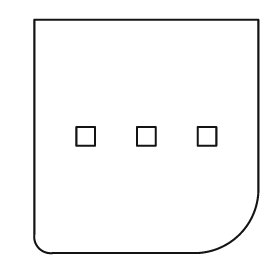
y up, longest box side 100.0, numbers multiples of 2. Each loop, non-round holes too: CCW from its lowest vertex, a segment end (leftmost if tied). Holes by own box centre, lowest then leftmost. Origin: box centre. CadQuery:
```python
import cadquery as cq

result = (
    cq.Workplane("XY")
    .moveTo(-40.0, -50.0)
    .lineTo(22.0, -50.0)
    .threePointArc((40.0, -42.0), (48.0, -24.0))
    .lineTo(48.0, 50.0)
    .lineTo(-48.0, 50.0)
    .lineTo(-48.0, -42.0)
    .threePointArc((-46.0, -48.0), (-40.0, -50.0))
    .close()
    .moveTo(-30.0, -4.0)
    .lineTo(-22.0, -4.0)
    .lineTo(-22.0, 4.0)
    .lineTo(-30.0, 4.0)
    .close()
    .moveTo(-4.0, -4.0)
    .lineTo(4.0, -4.0)
    .lineTo(4.0, 4.0)
    .lineTo(-4.0, 4.0)
    .close()
    .moveTo(22.0, -4.0)
    .lineTo(30.0, -4.0)
    .lineTo(30.0, 4.0)
    .lineTo(22.0, 4.0)
    .close()
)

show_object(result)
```